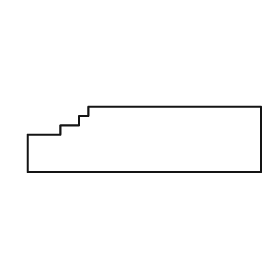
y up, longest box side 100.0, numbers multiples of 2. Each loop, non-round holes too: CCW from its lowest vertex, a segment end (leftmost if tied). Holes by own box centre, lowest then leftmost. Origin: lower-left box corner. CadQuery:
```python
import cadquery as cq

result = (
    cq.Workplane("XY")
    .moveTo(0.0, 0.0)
    .lineTo(100.0, 0.0)
    .lineTo(100.0, 28.0)
    .lineTo(26.0, 28.0)
    .lineTo(26.0, 24.0)
    .lineTo(22.0, 24.0)
    .lineTo(22.0, 20.0)
    .lineTo(14.0, 20.0)
    .lineTo(14.0, 16.0)
    .lineTo(0.0, 16.0)
    .close()
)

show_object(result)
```